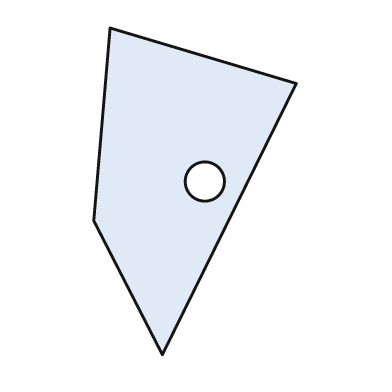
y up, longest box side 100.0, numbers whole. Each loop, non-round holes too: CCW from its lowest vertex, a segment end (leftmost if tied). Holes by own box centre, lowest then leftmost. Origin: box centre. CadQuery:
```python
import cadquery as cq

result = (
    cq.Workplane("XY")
    .moveTo(-10.0, -50.0)
    .lineTo(31.0, 33.0)
    .lineTo(-26.0, 50.0)
    .lineTo(-31.0, -9.0)
    .close()
    .moveTo(3.0, 3.0)
    .circle(6.0)
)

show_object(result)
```